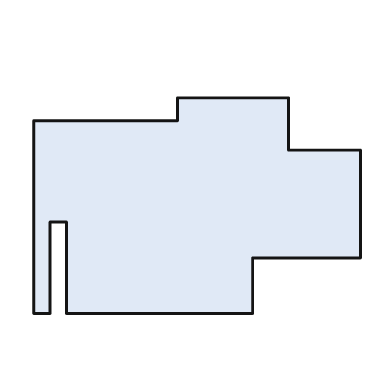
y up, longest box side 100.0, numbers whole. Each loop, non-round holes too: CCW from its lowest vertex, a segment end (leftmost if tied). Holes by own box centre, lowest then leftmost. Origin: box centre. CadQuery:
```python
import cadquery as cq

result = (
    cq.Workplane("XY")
    .moveTo(-50.0, -33.0)
    .lineTo(-45.0, -33.0)
    .lineTo(-45.0, -5.0)
    .lineTo(-40.0, -5.0)
    .lineTo(-40.0, -33.0)
    .lineTo(17.0, -33.0)
    .lineTo(17.0, -16.0)
    .lineTo(50.0, -16.0)
    .lineTo(50.0, 17.0)
    .lineTo(28.0, 17.0)
    .lineTo(28.0, 33.0)
    .lineTo(-6.0, 33.0)
    .lineTo(-6.0, 26.0)
    .lineTo(-50.0, 26.0)
    .close()
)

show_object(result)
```